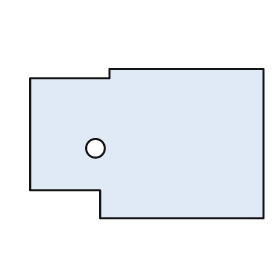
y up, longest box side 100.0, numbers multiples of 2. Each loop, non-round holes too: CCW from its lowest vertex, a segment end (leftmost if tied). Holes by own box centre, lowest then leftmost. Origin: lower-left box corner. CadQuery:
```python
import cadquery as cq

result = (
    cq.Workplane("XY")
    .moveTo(30.0, 0.0)
    .lineTo(100.0, 0.0)
    .lineTo(100.0, 64.0)
    .lineTo(34.0, 64.0)
    .lineTo(34.0, 60.0)
    .lineTo(0.0, 60.0)
    .lineTo(0.0, 12.0)
    .lineTo(30.0, 12.0)
    .close()
    .moveTo(28.0, 30.0)
    .circle(4.0)
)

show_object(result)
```